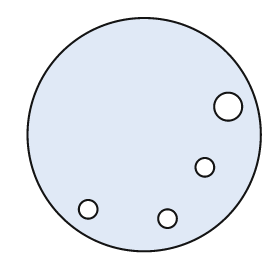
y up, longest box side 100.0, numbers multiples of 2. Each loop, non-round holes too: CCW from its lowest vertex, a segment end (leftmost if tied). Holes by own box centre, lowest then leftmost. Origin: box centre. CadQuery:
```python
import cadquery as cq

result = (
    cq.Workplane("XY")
    .moveTo(0.0, 0.0)
    .circle(50.0)
    .moveTo(10.0, -36.0)
    .circle(4.0)
    .moveTo(-24.0, -32.0)
    .circle(4.0)
    .moveTo(26.0, -14.0)
    .circle(4.0)
    .moveTo(36.0, 12.0)
    .circle(6.0)
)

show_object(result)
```